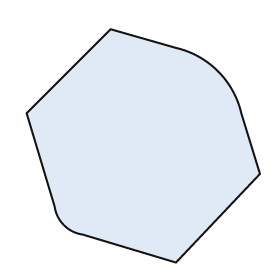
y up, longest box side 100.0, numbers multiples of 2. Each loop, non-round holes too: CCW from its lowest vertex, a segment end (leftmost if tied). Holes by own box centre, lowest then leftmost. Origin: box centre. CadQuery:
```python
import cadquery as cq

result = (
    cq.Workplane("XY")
    .moveTo(14.0, -50.0)
    .lineTo(50.0, -12.0)
    .lineTo(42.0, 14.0)
    .threePointArc((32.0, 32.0), (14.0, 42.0))
    .lineTo(-14.0, 50.0)
    .lineTo(-50.0, 14.0)
    .lineTo(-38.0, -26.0)
    .threePointArc((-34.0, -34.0), (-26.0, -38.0))
    .close()
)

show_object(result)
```